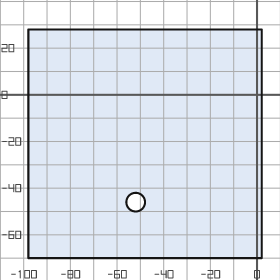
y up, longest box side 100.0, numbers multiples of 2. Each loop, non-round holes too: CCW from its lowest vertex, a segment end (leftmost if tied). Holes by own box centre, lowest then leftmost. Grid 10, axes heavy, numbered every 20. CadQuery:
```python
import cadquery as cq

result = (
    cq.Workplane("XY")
    .moveTo(-98.0, -70.0)
    .lineTo(2.0, -70.0)
    .lineTo(2.0, 28.0)
    .lineTo(-98.0, 28.0)
    .close()
    .moveTo(-52.0, -46.0)
    .circle(4.0)
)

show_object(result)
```